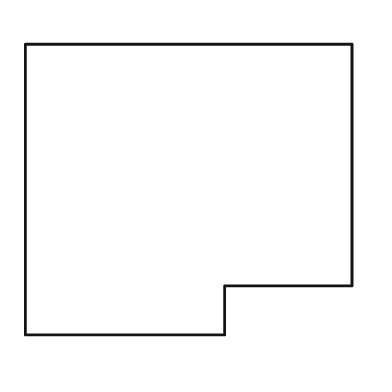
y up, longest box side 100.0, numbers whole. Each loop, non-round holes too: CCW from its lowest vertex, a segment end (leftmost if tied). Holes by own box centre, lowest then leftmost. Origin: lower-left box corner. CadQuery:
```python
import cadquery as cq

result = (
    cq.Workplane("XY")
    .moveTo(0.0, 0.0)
    .lineTo(61.0, 0.0)
    .lineTo(61.0, 15.0)
    .lineTo(100.0, 15.0)
    .lineTo(100.0, 89.0)
    .lineTo(0.0, 89.0)
    .close()
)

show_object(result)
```